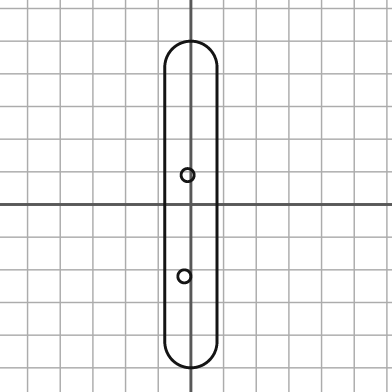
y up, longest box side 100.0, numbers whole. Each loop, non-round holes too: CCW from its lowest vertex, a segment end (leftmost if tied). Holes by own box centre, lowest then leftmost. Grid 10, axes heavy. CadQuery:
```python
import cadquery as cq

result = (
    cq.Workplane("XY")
    .moveTo(-8.0, -42.0)
    .threePointArc((0.0, -50.0), (8.0, -42.0))
    .lineTo(8.0, 42.0)
    .threePointArc((0.0, 50.0), (-8.0, 42.0))
    .close()
    .moveTo(-2.0, -22.0)
    .circle(2.0)
    .moveTo(-1.0, 9.0)
    .circle(2.0)
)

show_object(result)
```